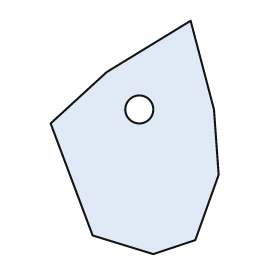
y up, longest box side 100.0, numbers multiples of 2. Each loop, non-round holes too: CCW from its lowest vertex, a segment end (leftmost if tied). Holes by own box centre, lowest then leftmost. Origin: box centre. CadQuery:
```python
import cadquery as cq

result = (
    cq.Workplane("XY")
    .moveTo(8.0, -50.0)
    .lineTo(26.0, -44.0)
    .lineTo(36.0, -16.0)
    .lineTo(34.0, 12.0)
    .lineTo(24.0, 50.0)
    .lineTo(-12.0, 28.0)
    .lineTo(-36.0, 6.0)
    .lineTo(-18.0, -42.0)
    .close()
    .moveTo(2.0, 12.0)
    .circle(6.0)
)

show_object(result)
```